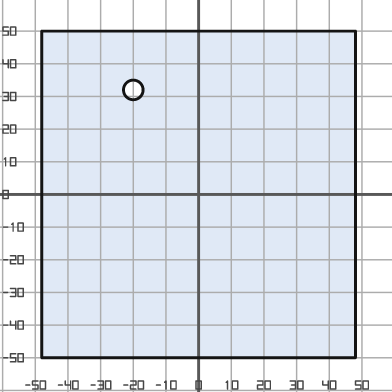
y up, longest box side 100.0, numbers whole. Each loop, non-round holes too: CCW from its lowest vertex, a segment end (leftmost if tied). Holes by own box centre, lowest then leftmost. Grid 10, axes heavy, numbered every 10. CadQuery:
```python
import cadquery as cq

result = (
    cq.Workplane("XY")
    .moveTo(-48.0, -50.0)
    .lineTo(48.0, -50.0)
    .lineTo(48.0, 50.0)
    .lineTo(-48.0, 50.0)
    .close()
    .moveTo(-20.0, 32.0)
    .circle(3.0)
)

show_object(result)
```